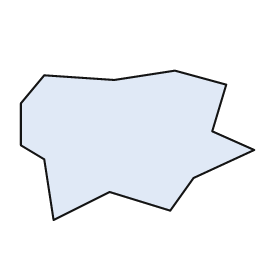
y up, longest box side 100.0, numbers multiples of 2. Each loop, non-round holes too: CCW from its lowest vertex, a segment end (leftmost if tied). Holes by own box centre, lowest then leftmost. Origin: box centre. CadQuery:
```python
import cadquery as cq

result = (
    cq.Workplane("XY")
    .moveTo(-36.0, -32.0)
    .lineTo(-12.0, -20.0)
    .lineTo(14.0, -28.0)
    .lineTo(24.0, -14.0)
    .lineTo(50.0, -2.0)
    .lineTo(32.0, 6.0)
    .lineTo(38.0, 26.0)
    .lineTo(16.0, 32.0)
    .lineTo(-10.0, 28.0)
    .lineTo(-40.0, 30.0)
    .lineTo(-50.0, 18.0)
    .lineTo(-50.0, 0.0)
    .lineTo(-40.0, -6.0)
    .close()
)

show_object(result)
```